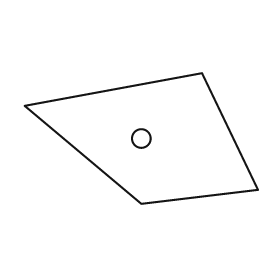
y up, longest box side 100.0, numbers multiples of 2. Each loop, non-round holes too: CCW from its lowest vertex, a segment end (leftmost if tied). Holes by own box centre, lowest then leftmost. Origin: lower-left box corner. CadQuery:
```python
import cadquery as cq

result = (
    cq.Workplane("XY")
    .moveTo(50.0, 0.0)
    .lineTo(100.0, 6.0)
    .lineTo(76.0, 56.0)
    .lineTo(0.0, 42.0)
    .close()
    .moveTo(50.0, 28.0)
    .circle(4.0)
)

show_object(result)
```